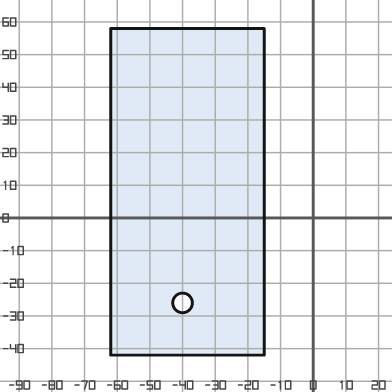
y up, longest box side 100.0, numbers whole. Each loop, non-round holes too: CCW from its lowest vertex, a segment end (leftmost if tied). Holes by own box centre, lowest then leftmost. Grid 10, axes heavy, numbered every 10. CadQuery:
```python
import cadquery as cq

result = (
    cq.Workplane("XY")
    .moveTo(-62.0, -42.0)
    .lineTo(-15.0, -42.0)
    .lineTo(-15.0, 58.0)
    .lineTo(-62.0, 58.0)
    .close()
    .moveTo(-40.0, -26.0)
    .circle(3.0)
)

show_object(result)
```